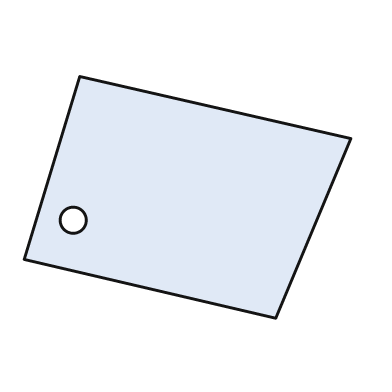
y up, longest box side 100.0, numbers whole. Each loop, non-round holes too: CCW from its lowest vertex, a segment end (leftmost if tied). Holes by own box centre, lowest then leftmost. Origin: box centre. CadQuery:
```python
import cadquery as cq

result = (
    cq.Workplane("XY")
    .moveTo(27.0, -37.0)
    .lineTo(50.0, 18.0)
    .lineTo(-33.0, 37.0)
    .lineTo(-50.0, -19.0)
    .close()
    .moveTo(-35.0, -7.0)
    .circle(4.0)
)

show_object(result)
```